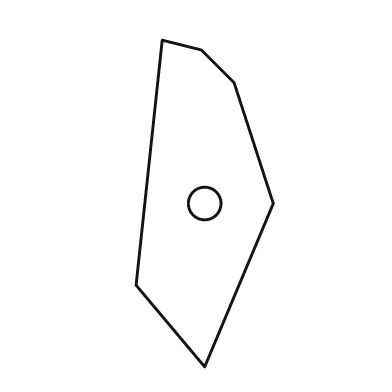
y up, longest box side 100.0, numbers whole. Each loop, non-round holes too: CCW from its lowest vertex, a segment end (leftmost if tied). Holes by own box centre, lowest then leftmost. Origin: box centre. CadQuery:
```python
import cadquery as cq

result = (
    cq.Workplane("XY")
    .moveTo(0.0, -50.0)
    .lineTo(21.0, 0.0)
    .lineTo(9.0, 37.0)
    .lineTo(-1.0, 47.0)
    .lineTo(-13.0, 50.0)
    .lineTo(-21.0, -25.0)
    .close()
    .moveTo(0.0, 0.0)
    .circle(5.0)
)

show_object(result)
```